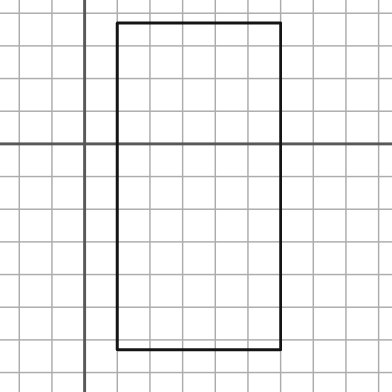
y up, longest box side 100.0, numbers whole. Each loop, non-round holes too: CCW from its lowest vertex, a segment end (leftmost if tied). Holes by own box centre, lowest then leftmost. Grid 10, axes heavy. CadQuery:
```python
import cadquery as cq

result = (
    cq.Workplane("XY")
    .moveTo(10.0, -63.0)
    .lineTo(60.0, -63.0)
    .lineTo(60.0, 37.0)
    .lineTo(10.0, 37.0)
    .close()
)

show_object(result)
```